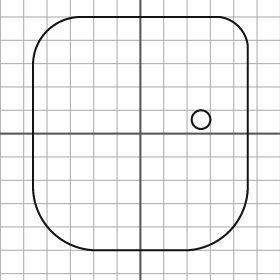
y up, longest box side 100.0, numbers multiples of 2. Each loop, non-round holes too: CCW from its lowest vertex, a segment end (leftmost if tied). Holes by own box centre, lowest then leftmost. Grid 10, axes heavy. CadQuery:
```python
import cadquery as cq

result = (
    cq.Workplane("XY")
    .moveTo(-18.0, -50.0)
    .lineTo(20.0, -50.0)
    .threePointArc((38.0, -42.0), (46.0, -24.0))
    .lineTo(46.0, 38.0)
    .threePointArc((42.0, 46.0), (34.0, 50.0))
    .lineTo(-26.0, 50.0)
    .threePointArc((-40.0, 44.0), (-46.0, 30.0))
    .lineTo(-46.0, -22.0)
    .threePointArc((-38.0, -42.0), (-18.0, -50.0))
    .close()
    .moveTo(26.0, 6.0)
    .circle(4.0)
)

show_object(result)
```